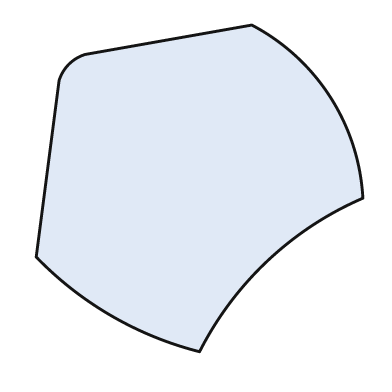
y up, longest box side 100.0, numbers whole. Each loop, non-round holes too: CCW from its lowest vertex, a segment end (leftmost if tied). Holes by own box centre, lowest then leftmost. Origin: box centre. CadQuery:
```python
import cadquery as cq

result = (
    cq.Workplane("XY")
    .moveTo(0.0, -50.0)
    .threePointArc((21.0, -22.0), (50.0, -3.0))
    .threePointArc((40.0, 28.0), (16.0, 50.0))
    .lineTo(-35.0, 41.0)
    .threePointArc((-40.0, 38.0), (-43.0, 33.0))
    .lineTo(-50.0, -21.0)
    .threePointArc((-27.0, -39.0), (0.0, -50.0))
    .close()
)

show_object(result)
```